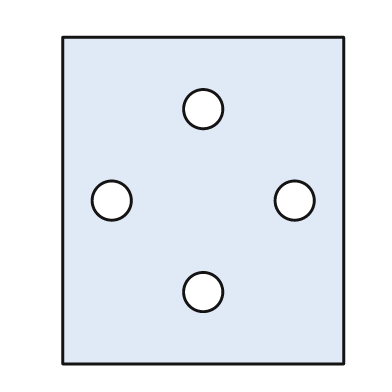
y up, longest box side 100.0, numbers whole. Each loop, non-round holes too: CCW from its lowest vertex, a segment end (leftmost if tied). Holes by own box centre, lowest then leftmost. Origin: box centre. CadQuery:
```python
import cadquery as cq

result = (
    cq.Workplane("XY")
    .moveTo(-43.0, -50.0)
    .lineTo(43.0, -50.0)
    .lineTo(43.0, 50.0)
    .lineTo(-43.0, 50.0)
    .close()
    .moveTo(0.0, -28.0)
    .circle(6.0)
    .moveTo(-28.0, 0.0)
    .circle(6.0)
    .moveTo(28.0, 0.0)
    .circle(6.0)
    .moveTo(0.0, 28.0)
    .circle(6.0)
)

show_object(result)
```